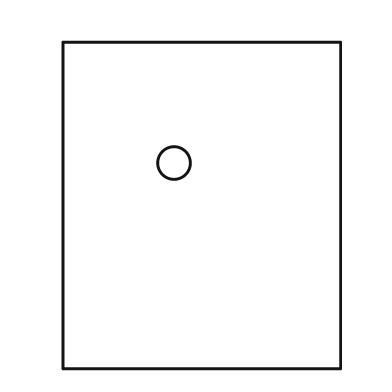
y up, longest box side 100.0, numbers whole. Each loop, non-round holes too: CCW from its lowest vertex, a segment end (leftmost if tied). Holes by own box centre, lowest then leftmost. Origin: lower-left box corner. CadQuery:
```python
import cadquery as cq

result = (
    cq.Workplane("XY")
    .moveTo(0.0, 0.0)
    .lineTo(85.0, 0.0)
    .lineTo(85.0, 100.0)
    .lineTo(0.0, 100.0)
    .close()
    .moveTo(34.0, 63.0)
    .circle(5.0)
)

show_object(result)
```